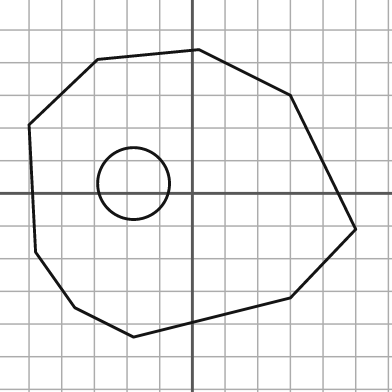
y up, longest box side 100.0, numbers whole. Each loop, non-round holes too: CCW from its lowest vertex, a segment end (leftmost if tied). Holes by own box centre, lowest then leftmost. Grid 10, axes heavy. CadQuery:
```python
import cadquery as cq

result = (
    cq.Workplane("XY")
    .moveTo(-18.0, -44.0)
    .lineTo(30.0, -32.0)
    .lineTo(50.0, -11.0)
    .lineTo(30.0, 30.0)
    .lineTo(2.0, 44.0)
    .lineTo(-29.0, 41.0)
    .lineTo(-50.0, 21.0)
    .lineTo(-48.0, -18.0)
    .lineTo(-36.0, -35.0)
    .close()
    .moveTo(-18.0, 3.0)
    .circle(11.0)
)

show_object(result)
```